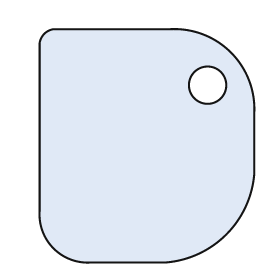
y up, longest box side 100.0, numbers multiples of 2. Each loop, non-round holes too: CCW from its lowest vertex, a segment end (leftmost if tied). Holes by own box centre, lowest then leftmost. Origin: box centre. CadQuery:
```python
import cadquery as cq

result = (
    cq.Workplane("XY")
    .moveTo(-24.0, -50.0)
    .lineTo(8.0, -50.0)
    .threePointArc((34.0, -38.0), (46.0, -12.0))
    .lineTo(46.0, 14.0)
    .threePointArc((36.0, 40.0), (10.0, 50.0))
    .lineTo(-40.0, 50.0)
    .threePointArc((-44.0, 48.0), (-46.0, 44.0))
    .lineTo(-46.0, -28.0)
    .threePointArc((-40.0, -44.0), (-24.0, -50.0))
    .close()
    .moveTo(26.0, 26.0)
    .circle(8.0)
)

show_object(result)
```